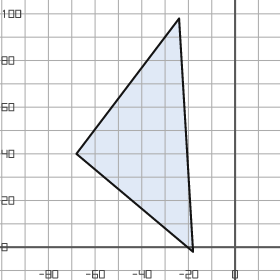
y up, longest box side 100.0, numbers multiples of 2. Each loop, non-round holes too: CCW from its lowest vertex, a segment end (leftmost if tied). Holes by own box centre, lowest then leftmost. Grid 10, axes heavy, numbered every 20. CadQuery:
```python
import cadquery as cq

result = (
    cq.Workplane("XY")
    .moveTo(-18.0, -2.0)
    .lineTo(-24.0, 98.0)
    .lineTo(-68.0, 40.0)
    .close()
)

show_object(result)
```